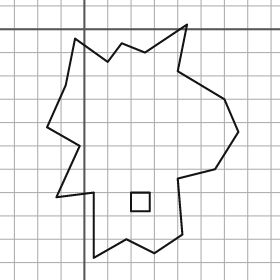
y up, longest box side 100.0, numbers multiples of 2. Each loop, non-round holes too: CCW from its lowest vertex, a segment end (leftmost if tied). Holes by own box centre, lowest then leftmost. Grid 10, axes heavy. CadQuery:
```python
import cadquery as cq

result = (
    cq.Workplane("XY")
    .moveTo(4.0, -98.0)
    .lineTo(18.0, -90.0)
    .lineTo(30.0, -96.0)
    .lineTo(42.0, -88.0)
    .lineTo(40.0, -64.0)
    .lineTo(56.0, -60.0)
    .lineTo(66.0, -44.0)
    .lineTo(60.0, -30.0)
    .lineTo(40.0, -18.0)
    .lineTo(44.0, 2.0)
    .lineTo(26.0, -10.0)
    .lineTo(16.0, -6.0)
    .lineTo(10.0, -14.0)
    .lineTo(-4.0, -4.0)
    .lineTo(-8.0, -24.0)
    .lineTo(-16.0, -42.0)
    .lineTo(-2.0, -50.0)
    .lineTo(-12.0, -72.0)
    .lineTo(4.0, -70.0)
    .close()
    .moveTo(20.0, -78.0)
    .lineTo(28.0, -78.0)
    .lineTo(28.0, -70.0)
    .lineTo(20.0, -70.0)
    .close()
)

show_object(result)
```